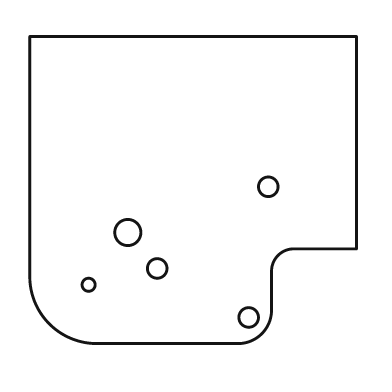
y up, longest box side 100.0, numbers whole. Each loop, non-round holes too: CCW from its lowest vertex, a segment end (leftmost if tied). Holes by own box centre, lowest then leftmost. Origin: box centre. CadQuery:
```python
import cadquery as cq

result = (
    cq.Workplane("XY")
    .moveTo(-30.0, -47.0)
    .lineTo(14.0, -47.0)
    .threePointArc((21.0, -44.0), (24.0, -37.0))
    .lineTo(24.0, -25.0)
    .threePointArc((26.0, -20.0), (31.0, -18.0))
    .lineTo(50.0, -18.0)
    .lineTo(50.0, 47.0)
    .lineTo(-50.0, 47.0)
    .lineTo(-50.0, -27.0)
    .threePointArc((-44.0, -41.0), (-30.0, -47.0))
    .close()
    .moveTo(17.0, -39.0)
    .circle(3.0)
    .moveTo(-32.0, -29.0)
    .circle(2.0)
    .moveTo(-11.0, -24.0)
    .circle(3.0)
    .moveTo(-20.0, -13.0)
    .circle(4.0)
    .moveTo(23.0, 1.0)
    .circle(3.0)
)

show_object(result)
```